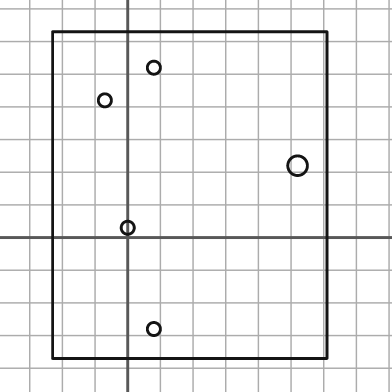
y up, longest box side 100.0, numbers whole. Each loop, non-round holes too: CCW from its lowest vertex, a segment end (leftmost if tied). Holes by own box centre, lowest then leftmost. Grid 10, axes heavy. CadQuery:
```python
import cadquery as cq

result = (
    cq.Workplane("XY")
    .moveTo(-23.0, -37.0)
    .lineTo(61.0, -37.0)
    .lineTo(61.0, 63.0)
    .lineTo(-23.0, 63.0)
    .close()
    .moveTo(8.0, -28.0)
    .circle(2.0)
    .moveTo(0.0, 3.0)
    .circle(2.0)
    .moveTo(52.0, 22.0)
    .circle(3.0)
    .moveTo(-7.0, 42.0)
    .circle(2.0)
    .moveTo(8.0, 52.0)
    .circle(2.0)
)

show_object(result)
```